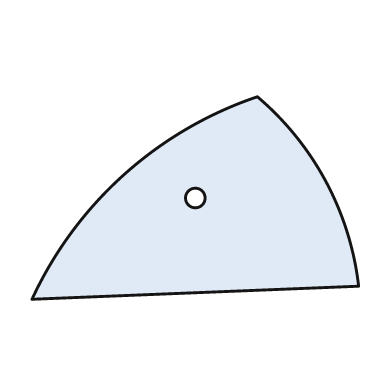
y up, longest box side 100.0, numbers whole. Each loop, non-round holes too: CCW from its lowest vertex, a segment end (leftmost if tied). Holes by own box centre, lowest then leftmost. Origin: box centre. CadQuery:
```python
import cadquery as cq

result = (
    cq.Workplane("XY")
    .moveTo(-50.0, -31.0)
    .lineTo(50.0, -27.0)
    .threePointArc((40.0, 5.0), (19.0, 31.0))
    .threePointArc((-22.0, 7.0), (-50.0, -31.0))
    .close()
    .moveTo(0.0, 0.0)
    .circle(3.0)
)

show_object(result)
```